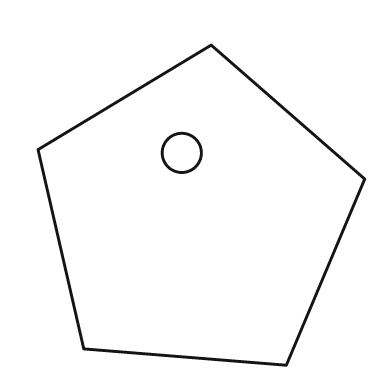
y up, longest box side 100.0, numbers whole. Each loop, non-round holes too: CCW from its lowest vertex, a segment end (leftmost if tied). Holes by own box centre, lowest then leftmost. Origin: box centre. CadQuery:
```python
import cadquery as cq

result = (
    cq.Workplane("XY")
    .moveTo(26.0, -49.0)
    .lineTo(50.0, 8.0)
    .lineTo(3.0, 49.0)
    .lineTo(-50.0, 17.0)
    .lineTo(-36.0, -44.0)
    .close()
    .moveTo(-6.0, 16.0)
    .circle(6.0)
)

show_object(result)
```